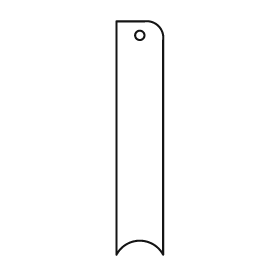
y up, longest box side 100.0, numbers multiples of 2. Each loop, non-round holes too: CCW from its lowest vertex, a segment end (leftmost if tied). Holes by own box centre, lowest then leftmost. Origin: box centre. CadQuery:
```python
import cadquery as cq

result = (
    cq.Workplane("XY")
    .moveTo(-10.0, -50.0)
    .threePointArc((0.0, -44.0), (10.0, -50.0))
    .lineTo(10.0, 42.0)
    .threePointArc((8.0, 48.0), (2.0, 50.0))
    .lineTo(-10.0, 50.0)
    .close()
    .moveTo(0.0, 44.0)
    .circle(2.0)
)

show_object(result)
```